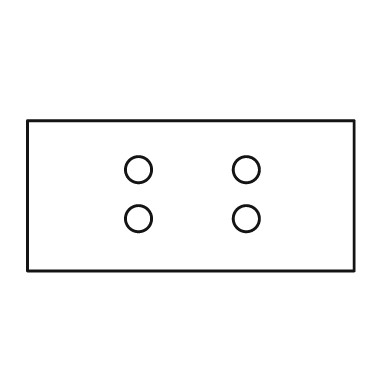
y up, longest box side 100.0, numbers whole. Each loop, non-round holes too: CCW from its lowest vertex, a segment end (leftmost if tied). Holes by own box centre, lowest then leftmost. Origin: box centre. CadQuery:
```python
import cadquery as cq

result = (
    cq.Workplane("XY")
    .moveTo(-50.0, -23.0)
    .lineTo(50.0, -23.0)
    .lineTo(50.0, 23.0)
    .lineTo(-50.0, 23.0)
    .close()
    .moveTo(-16.0, -7.0)
    .circle(4.0)
    .moveTo(17.0, -7.0)
    .circle(4.0)
    .moveTo(-16.0, 8.0)
    .circle(4.0)
    .moveTo(17.0, 8.0)
    .circle(4.0)
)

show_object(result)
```